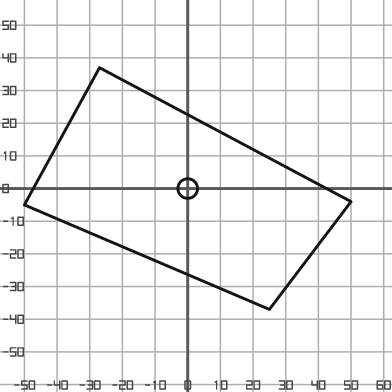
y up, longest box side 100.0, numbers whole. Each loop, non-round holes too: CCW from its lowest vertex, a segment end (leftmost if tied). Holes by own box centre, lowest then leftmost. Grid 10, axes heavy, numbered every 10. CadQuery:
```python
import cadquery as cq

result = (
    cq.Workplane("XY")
    .moveTo(25.0, -37.0)
    .lineTo(50.0, -4.0)
    .lineTo(-27.0, 37.0)
    .lineTo(-50.0, -5.0)
    .close()
    .moveTo(0.0, 0.0)
    .circle(3.0)
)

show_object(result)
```